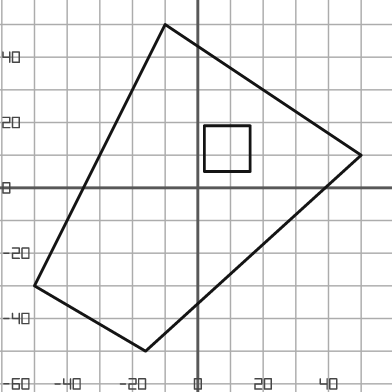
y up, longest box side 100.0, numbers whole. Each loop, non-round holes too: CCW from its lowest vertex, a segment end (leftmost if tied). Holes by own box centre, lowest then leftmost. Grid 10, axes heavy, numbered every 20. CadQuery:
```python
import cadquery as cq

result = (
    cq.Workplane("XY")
    .moveTo(-16.0, -50.0)
    .lineTo(50.0, 10.0)
    .lineTo(-10.0, 50.0)
    .lineTo(-50.0, -30.0)
    .close()
    .moveTo(2.0, 5.0)
    .lineTo(16.0, 5.0)
    .lineTo(16.0, 19.0)
    .lineTo(2.0, 19.0)
    .close()
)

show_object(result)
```